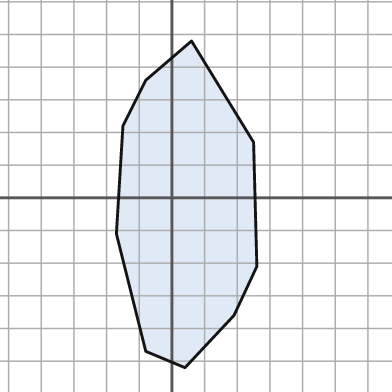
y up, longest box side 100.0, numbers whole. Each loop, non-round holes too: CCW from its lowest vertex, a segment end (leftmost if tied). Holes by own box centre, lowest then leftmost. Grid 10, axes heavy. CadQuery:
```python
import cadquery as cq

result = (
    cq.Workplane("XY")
    .moveTo(4.0, -52.0)
    .lineTo(19.0, -36.0)
    .lineTo(26.0, -21.0)
    .lineTo(25.0, 17.0)
    .lineTo(6.0, 48.0)
    .lineTo(-8.0, 36.0)
    .lineTo(-15.0, 22.0)
    .lineTo(-17.0, -11.0)
    .lineTo(-8.0, -47.0)
    .close()
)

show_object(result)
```